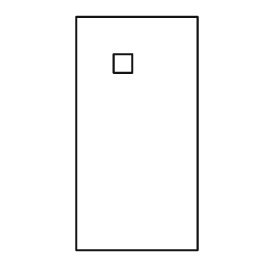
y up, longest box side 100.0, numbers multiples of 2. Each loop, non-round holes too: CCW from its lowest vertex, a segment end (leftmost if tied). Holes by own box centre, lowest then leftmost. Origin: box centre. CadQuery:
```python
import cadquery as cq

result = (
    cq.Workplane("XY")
    .moveTo(-26.0, -50.0)
    .lineTo(26.0, -50.0)
    .lineTo(26.0, 50.0)
    .lineTo(-26.0, 50.0)
    .close()
    .moveTo(-10.0, 26.0)
    .lineTo(-2.0, 26.0)
    .lineTo(-2.0, 34.0)
    .lineTo(-10.0, 34.0)
    .close()
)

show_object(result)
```